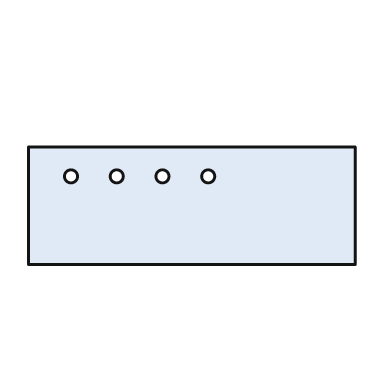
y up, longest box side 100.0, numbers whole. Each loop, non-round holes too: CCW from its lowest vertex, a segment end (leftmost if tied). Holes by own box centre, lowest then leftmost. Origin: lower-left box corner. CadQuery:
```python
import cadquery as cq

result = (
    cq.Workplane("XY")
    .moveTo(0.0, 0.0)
    .lineTo(100.0, 0.0)
    .lineTo(100.0, 36.0)
    .lineTo(0.0, 36.0)
    .close()
    .moveTo(13.0, 27.0)
    .circle(2.0)
    .moveTo(27.0, 27.0)
    .circle(2.0)
    .moveTo(41.0, 27.0)
    .circle(2.0)
    .moveTo(55.0, 27.0)
    .circle(2.0)
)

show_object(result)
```